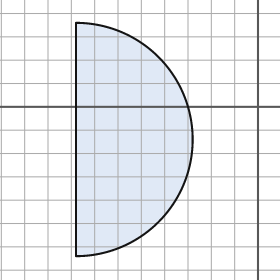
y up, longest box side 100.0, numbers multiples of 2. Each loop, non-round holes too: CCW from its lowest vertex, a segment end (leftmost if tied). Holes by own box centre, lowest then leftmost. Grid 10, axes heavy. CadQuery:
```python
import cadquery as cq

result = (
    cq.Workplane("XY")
    .moveTo(-78.0, -64.0)
    .threePointArc((-28.0, -14.0), (-78.0, 36.0))
    .close()
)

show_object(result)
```